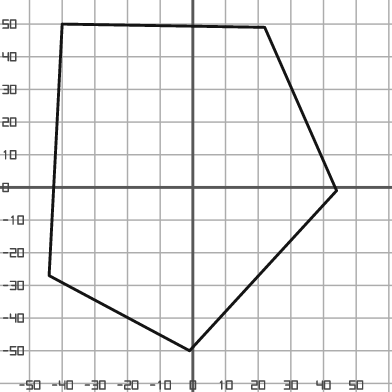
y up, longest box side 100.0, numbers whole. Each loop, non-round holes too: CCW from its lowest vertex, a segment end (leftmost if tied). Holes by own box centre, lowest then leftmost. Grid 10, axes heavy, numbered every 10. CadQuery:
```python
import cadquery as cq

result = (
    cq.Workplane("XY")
    .moveTo(-1.0, -50.0)
    .lineTo(44.0, -1.0)
    .lineTo(22.0, 49.0)
    .lineTo(-40.0, 50.0)
    .lineTo(-44.0, -27.0)
    .close()
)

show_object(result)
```